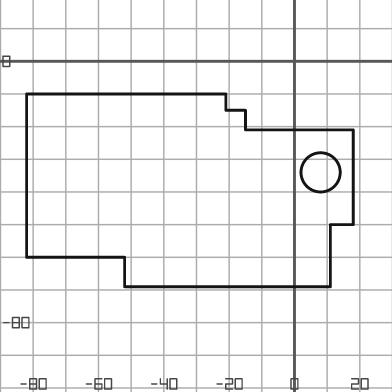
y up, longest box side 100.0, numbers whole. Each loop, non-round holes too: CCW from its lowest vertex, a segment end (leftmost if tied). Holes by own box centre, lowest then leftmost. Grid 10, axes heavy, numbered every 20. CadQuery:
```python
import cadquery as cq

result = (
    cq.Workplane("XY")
    .moveTo(-52.0, -69.0)
    .lineTo(11.0, -69.0)
    .lineTo(11.0, -50.0)
    .lineTo(18.0, -50.0)
    .lineTo(18.0, -21.0)
    .lineTo(-15.0, -21.0)
    .lineTo(-15.0, -15.0)
    .lineTo(-21.0, -15.0)
    .lineTo(-21.0, -10.0)
    .lineTo(-82.0, -10.0)
    .lineTo(-82.0, -60.0)
    .lineTo(-52.0, -60.0)
    .close()
    .moveTo(8.0, -34.0)
    .circle(6.0)
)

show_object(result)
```